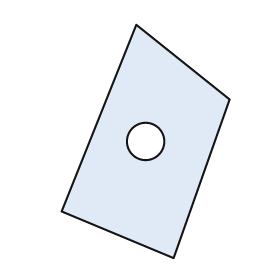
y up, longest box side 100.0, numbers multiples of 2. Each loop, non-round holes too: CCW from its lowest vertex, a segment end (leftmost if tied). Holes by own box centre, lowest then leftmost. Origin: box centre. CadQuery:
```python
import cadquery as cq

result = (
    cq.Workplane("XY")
    .moveTo(12.0, -50.0)
    .lineTo(36.0, 18.0)
    .lineTo(-4.0, 50.0)
    .lineTo(-36.0, -30.0)
    .close()
    .moveTo(0.0, 0.0)
    .circle(8.0)
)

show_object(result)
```